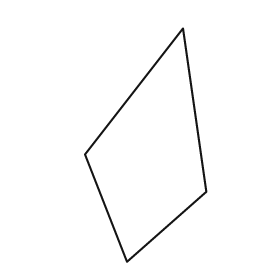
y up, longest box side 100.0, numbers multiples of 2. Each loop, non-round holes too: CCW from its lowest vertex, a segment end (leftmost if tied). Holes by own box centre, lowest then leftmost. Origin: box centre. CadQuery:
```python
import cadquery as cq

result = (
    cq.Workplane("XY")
    .moveTo(-8.0, -50.0)
    .lineTo(26.0, -20.0)
    .lineTo(16.0, 50.0)
    .lineTo(-26.0, -4.0)
    .close()
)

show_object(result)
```